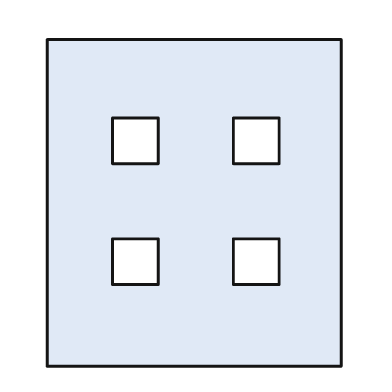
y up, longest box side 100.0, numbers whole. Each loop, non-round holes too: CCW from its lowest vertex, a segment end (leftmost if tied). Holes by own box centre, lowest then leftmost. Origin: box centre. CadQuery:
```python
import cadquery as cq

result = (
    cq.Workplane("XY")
    .moveTo(-45.0, -50.0)
    .lineTo(45.0, -50.0)
    .lineTo(45.0, 50.0)
    .lineTo(-45.0, 50.0)
    .close()
    .moveTo(-25.0, -25.0)
    .lineTo(-11.0, -25.0)
    .lineTo(-11.0, -11.0)
    .lineTo(-25.0, -11.0)
    .close()
    .moveTo(12.0, -25.0)
    .lineTo(26.0, -25.0)
    .lineTo(26.0, -11.0)
    .lineTo(12.0, -11.0)
    .close()
    .moveTo(-25.0, 12.0)
    .lineTo(-11.0, 12.0)
    .lineTo(-11.0, 26.0)
    .lineTo(-25.0, 26.0)
    .close()
    .moveTo(12.0, 12.0)
    .lineTo(26.0, 12.0)
    .lineTo(26.0, 26.0)
    .lineTo(12.0, 26.0)
    .close()
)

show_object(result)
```